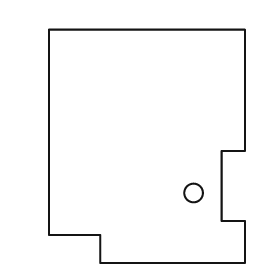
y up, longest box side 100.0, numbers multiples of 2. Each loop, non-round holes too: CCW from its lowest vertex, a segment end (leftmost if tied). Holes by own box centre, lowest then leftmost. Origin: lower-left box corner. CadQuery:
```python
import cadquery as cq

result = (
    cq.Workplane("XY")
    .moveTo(22.0, 0.0)
    .lineTo(84.0, 0.0)
    .lineTo(84.0, 18.0)
    .lineTo(74.0, 18.0)
    .lineTo(74.0, 48.0)
    .lineTo(84.0, 48.0)
    .lineTo(84.0, 100.0)
    .lineTo(0.0, 100.0)
    .lineTo(0.0, 12.0)
    .lineTo(22.0, 12.0)
    .close()
    .moveTo(62.0, 30.0)
    .circle(4.0)
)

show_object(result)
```